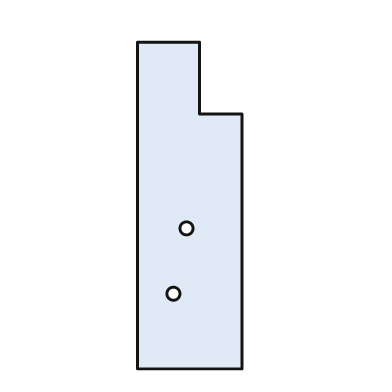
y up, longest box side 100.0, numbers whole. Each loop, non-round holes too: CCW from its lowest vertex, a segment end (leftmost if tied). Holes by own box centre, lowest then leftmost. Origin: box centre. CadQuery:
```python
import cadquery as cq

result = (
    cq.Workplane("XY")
    .moveTo(-16.0, -50.0)
    .lineTo(16.0, -50.0)
    .lineTo(16.0, 28.0)
    .lineTo(3.0, 28.0)
    .lineTo(3.0, 50.0)
    .lineTo(-16.0, 50.0)
    .close()
    .moveTo(-5.0, -27.0)
    .circle(2.0)
    .moveTo(-1.0, -7.0)
    .circle(2.0)
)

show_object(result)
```